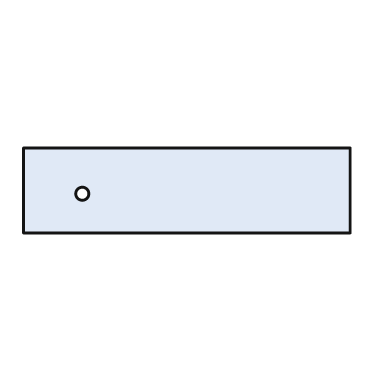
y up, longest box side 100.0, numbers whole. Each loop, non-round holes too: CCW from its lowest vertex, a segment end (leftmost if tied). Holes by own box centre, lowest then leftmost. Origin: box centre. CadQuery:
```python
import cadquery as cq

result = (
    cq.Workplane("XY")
    .moveTo(-50.0, -13.0)
    .lineTo(50.0, -13.0)
    .lineTo(50.0, 13.0)
    .lineTo(-50.0, 13.0)
    .close()
    .moveTo(-32.0, -1.0)
    .circle(2.0)
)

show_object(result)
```